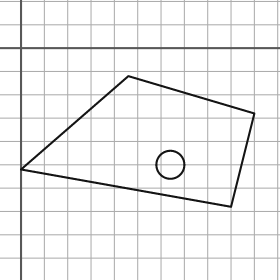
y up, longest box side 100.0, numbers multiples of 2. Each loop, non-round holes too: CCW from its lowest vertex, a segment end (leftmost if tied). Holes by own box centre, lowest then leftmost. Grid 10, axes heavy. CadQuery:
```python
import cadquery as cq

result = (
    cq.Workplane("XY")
    .moveTo(90.0, -68.0)
    .lineTo(100.0, -28.0)
    .lineTo(46.0, -12.0)
    .lineTo(0.0, -52.0)
    .close()
    .moveTo(64.0, -50.0)
    .circle(6.0)
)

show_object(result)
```